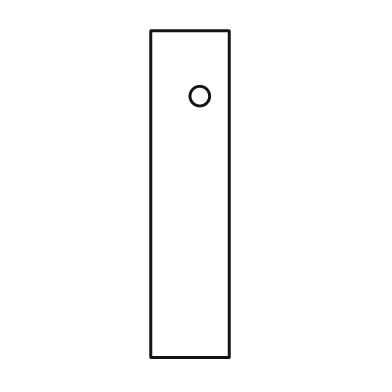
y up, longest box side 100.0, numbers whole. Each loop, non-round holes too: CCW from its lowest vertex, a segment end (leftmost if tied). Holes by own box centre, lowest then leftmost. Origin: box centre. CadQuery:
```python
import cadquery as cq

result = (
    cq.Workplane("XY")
    .moveTo(-12.0, -50.0)
    .lineTo(12.0, -50.0)
    .lineTo(12.0, 50.0)
    .lineTo(-12.0, 50.0)
    .close()
    .moveTo(3.0, 30.0)
    .circle(3.0)
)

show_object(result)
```